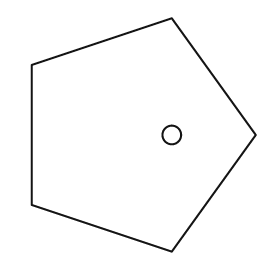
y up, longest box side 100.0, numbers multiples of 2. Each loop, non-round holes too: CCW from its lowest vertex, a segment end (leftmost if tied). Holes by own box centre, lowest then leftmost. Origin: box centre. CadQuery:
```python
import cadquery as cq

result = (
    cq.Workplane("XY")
    .moveTo(12.0, -50.0)
    .lineTo(48.0, 0.0)
    .lineTo(12.0, 50.0)
    .lineTo(-48.0, 30.0)
    .lineTo(-48.0, -30.0)
    .close()
    .moveTo(12.0, 0.0)
    .circle(4.0)
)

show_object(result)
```